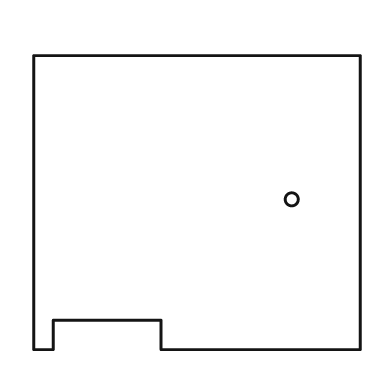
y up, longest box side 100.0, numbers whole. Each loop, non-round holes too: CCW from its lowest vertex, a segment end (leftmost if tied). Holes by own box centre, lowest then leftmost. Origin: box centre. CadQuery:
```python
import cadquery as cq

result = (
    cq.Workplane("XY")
    .moveTo(-50.0, -45.0)
    .lineTo(-44.0, -45.0)
    .lineTo(-44.0, -36.0)
    .lineTo(-11.0, -36.0)
    .lineTo(-11.0, -45.0)
    .lineTo(50.0, -45.0)
    .lineTo(50.0, 45.0)
    .lineTo(-50.0, 45.0)
    .close()
    .moveTo(29.0, 1.0)
    .circle(2.0)
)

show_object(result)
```